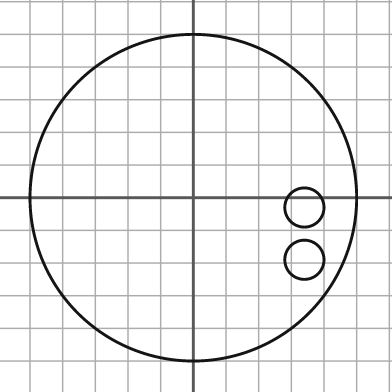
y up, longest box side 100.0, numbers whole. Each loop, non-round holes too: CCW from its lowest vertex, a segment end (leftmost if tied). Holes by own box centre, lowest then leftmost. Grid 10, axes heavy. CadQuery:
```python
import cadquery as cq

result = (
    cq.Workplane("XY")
    .moveTo(0.0, 0.0)
    .circle(50.0)
    .moveTo(34.0, -19.0)
    .circle(6.0)
    .moveTo(34.0, -3.0)
    .circle(6.0)
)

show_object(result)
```